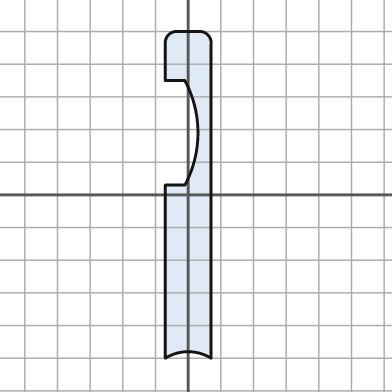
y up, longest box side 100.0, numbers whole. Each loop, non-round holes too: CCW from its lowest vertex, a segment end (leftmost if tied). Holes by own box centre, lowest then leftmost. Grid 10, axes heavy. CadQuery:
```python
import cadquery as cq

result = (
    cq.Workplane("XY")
    .moveTo(-7.0, -50.0)
    .threePointArc((0.0, -48.0), (7.0, -50.0))
    .lineTo(7.0, 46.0)
    .threePointArc((6.0, 49.0), (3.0, 50.0))
    .lineTo(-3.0, 50.0)
    .threePointArc((-6.0, 49.0), (-7.0, 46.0))
    .lineTo(-7.0, 35.0)
    .lineTo(-1.0, 35.0)
    .threePointArc((3.0, 19.0), (-1.0, 3.0))
    .lineTo(-7.0, 3.0)
    .close()
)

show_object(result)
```